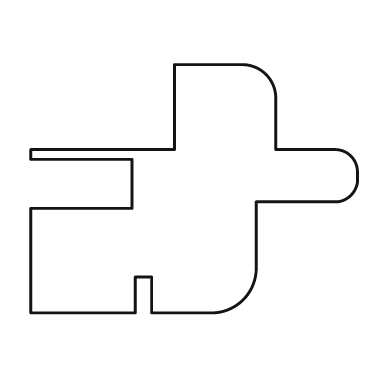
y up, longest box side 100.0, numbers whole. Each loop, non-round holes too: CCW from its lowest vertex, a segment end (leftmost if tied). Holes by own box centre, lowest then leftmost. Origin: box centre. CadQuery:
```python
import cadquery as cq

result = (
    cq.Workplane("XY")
    .moveTo(-50.0, -38.0)
    .lineTo(-18.0, -38.0)
    .lineTo(-18.0, -27.0)
    .lineTo(-13.0, -27.0)
    .lineTo(-13.0, -38.0)
    .lineTo(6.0, -38.0)
    .threePointArc((15.0, -34.0), (19.0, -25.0))
    .lineTo(19.0, -4.0)
    .lineTo(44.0, -4.0)
    .threePointArc((48.0, -2.0), (50.0, 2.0))
    .lineTo(50.0, 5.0)
    .threePointArc((48.0, 10.0), (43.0, 12.0))
    .lineTo(25.0, 12.0)
    .lineTo(25.0, 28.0)
    .threePointArc((22.0, 35.0), (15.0, 38.0))
    .lineTo(-6.0, 38.0)
    .lineTo(-6.0, 12.0)
    .lineTo(-50.0, 12.0)
    .lineTo(-50.0, 9.0)
    .lineTo(-19.0, 9.0)
    .lineTo(-19.0, -6.0)
    .lineTo(-50.0, -6.0)
    .close()
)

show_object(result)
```